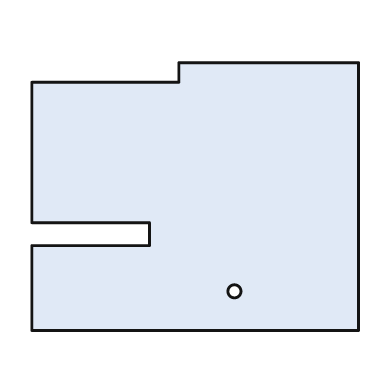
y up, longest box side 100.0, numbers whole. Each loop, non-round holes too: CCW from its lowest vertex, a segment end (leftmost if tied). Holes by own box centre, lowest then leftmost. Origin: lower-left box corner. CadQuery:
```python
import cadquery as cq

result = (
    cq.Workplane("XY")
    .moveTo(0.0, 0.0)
    .lineTo(100.0, 0.0)
    .lineTo(100.0, 82.0)
    .lineTo(45.0, 82.0)
    .lineTo(45.0, 76.0)
    .lineTo(0.0, 76.0)
    .lineTo(0.0, 33.0)
    .lineTo(36.0, 33.0)
    .lineTo(36.0, 26.0)
    .lineTo(0.0, 26.0)
    .close()
    .moveTo(62.0, 12.0)
    .circle(2.0)
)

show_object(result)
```